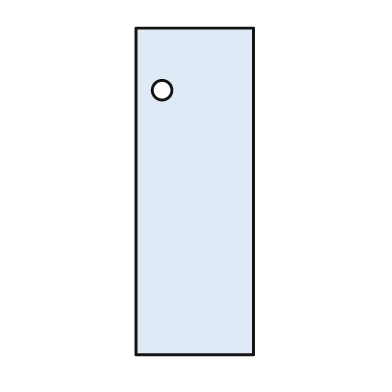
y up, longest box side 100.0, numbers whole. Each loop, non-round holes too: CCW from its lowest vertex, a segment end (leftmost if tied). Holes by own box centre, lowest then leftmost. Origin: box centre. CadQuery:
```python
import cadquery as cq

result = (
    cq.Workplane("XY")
    .moveTo(-18.0, -50.0)
    .lineTo(18.0, -50.0)
    .lineTo(18.0, 50.0)
    .lineTo(-18.0, 50.0)
    .close()
    .moveTo(-10.0, 31.0)
    .circle(3.0)
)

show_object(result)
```